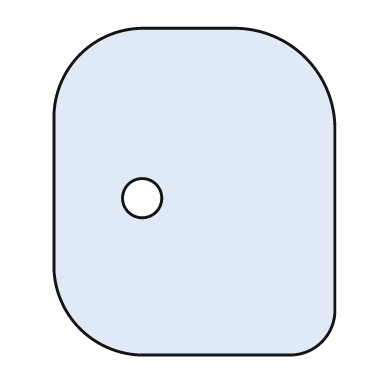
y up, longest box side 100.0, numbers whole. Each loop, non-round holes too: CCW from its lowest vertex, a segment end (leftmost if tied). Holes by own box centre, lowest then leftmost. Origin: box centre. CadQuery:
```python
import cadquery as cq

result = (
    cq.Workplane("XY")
    .moveTo(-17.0, -50.0)
    .lineTo(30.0, -50.0)
    .threePointArc((39.0, -46.0), (43.0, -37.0))
    .lineTo(43.0, 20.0)
    .threePointArc((34.0, 41.0), (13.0, 50.0))
    .lineTo(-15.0, 50.0)
    .threePointArc((-35.0, 42.0), (-43.0, 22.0))
    .lineTo(-43.0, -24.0)
    .threePointArc((-35.0, -42.0), (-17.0, -50.0))
    .close()
    .moveTo(-16.0, -2.0)
    .circle(6.0)
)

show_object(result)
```